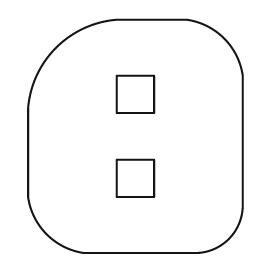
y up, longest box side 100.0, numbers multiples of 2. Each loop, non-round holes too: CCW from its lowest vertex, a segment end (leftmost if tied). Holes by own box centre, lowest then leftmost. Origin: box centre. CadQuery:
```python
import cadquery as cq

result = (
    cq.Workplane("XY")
    .moveTo(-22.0, -50.0)
    .lineTo(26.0, -50.0)
    .threePointArc((40.0, -44.0), (46.0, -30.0))
    .lineTo(46.0, 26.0)
    .threePointArc((38.0, 42.0), (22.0, 50.0))
    .lineTo(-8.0, 50.0)
    .threePointArc((-34.0, 38.0), (-46.0, 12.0))
    .lineTo(-46.0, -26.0)
    .threePointArc((-38.0, -42.0), (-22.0, -50.0))
    .close()
    .moveTo(-8.0, -26.0)
    .lineTo(8.0, -26.0)
    .lineTo(8.0, -10.0)
    .lineTo(-8.0, -10.0)
    .close()
    .moveTo(-8.0, 10.0)
    .lineTo(8.0, 10.0)
    .lineTo(8.0, 26.0)
    .lineTo(-8.0, 26.0)
    .close()
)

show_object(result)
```